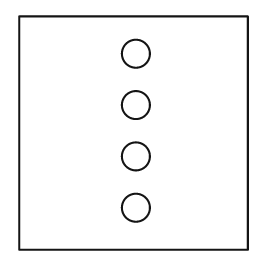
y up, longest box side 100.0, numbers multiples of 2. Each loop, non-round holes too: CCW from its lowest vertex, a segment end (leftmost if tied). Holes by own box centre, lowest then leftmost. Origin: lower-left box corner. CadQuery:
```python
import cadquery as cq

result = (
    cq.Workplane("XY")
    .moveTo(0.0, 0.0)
    .lineTo(98.0, 0.0)
    .lineTo(98.0, 100.0)
    .lineTo(0.0, 100.0)
    .close()
    .moveTo(50.0, 18.0)
    .circle(6.0)
    .moveTo(50.0, 40.0)
    .circle(6.0)
    .moveTo(50.0, 62.0)
    .circle(6.0)
    .moveTo(50.0, 84.0)
    .circle(6.0)
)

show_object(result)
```